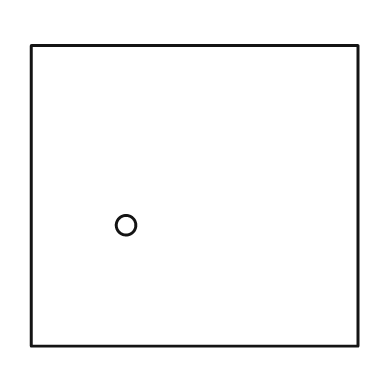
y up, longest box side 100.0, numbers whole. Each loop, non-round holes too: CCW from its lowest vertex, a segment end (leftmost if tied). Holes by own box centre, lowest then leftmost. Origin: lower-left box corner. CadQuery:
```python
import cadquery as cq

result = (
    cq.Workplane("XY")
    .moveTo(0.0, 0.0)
    .lineTo(100.0, 0.0)
    .lineTo(100.0, 92.0)
    .lineTo(0.0, 92.0)
    .close()
    .moveTo(29.0, 37.0)
    .circle(3.0)
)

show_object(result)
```